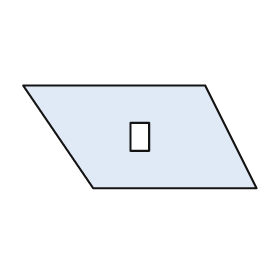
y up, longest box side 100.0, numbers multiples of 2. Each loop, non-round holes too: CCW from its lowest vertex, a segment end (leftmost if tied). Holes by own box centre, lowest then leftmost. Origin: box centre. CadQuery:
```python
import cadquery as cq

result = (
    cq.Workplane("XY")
    .moveTo(-20.0, -22.0)
    .lineTo(50.0, -22.0)
    .lineTo(28.0, 22.0)
    .lineTo(-50.0, 22.0)
    .close()
    .moveTo(-4.0, -6.0)
    .lineTo(4.0, -6.0)
    .lineTo(4.0, 6.0)
    .lineTo(-4.0, 6.0)
    .close()
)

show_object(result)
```